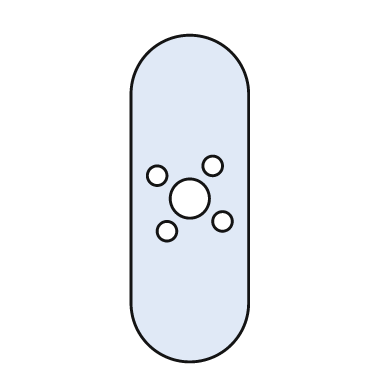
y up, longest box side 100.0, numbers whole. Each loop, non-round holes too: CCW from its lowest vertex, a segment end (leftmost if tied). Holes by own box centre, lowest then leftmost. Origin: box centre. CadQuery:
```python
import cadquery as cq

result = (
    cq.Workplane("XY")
    .moveTo(-18.0, -32.0)
    .threePointArc((0.0, -50.0), (18.0, -32.0))
    .lineTo(18.0, 32.0)
    .threePointArc((0.0, 50.0), (-18.0, 32.0))
    .close()
    .moveTo(-7.0, -10.0)
    .circle(3.0)
    .moveTo(10.0, -7.0)
    .circle(3.0)
    .moveTo(0.0, 0.0)
    .circle(6.0)
    .moveTo(-10.0, 7.0)
    .circle(3.0)
    .moveTo(7.0, 10.0)
    .circle(3.0)
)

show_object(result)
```